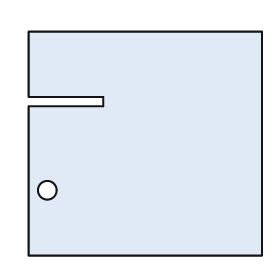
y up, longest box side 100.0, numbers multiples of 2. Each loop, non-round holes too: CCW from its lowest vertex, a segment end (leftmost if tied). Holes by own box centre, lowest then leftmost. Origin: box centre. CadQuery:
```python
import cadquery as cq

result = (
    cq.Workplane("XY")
    .moveTo(-50.0, -48.0)
    .lineTo(50.0, -48.0)
    .lineTo(50.0, 48.0)
    .lineTo(-50.0, 48.0)
    .lineTo(-50.0, 20.0)
    .lineTo(-18.0, 20.0)
    .lineTo(-18.0, 16.0)
    .lineTo(-50.0, 16.0)
    .close()
    .moveTo(-42.0, -20.0)
    .circle(4.0)
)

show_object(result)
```